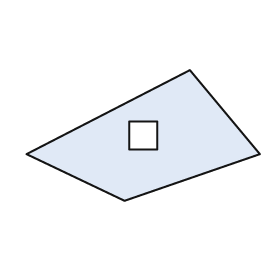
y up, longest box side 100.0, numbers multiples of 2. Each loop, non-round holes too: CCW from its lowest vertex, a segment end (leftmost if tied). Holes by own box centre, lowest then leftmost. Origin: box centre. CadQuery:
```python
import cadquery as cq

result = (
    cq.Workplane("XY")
    .moveTo(-8.0, -28.0)
    .lineTo(50.0, -8.0)
    .lineTo(20.0, 28.0)
    .lineTo(-50.0, -8.0)
    .close()
    .moveTo(-6.0, -6.0)
    .lineTo(6.0, -6.0)
    .lineTo(6.0, 6.0)
    .lineTo(-6.0, 6.0)
    .close()
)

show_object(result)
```